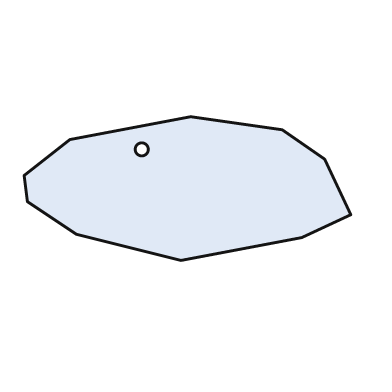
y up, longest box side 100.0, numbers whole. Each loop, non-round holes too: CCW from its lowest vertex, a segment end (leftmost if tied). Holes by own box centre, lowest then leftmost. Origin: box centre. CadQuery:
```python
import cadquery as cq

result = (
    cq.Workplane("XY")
    .moveTo(-2.0, -22.0)
    .lineTo(35.0, -15.0)
    .lineTo(50.0, -8.0)
    .lineTo(42.0, 9.0)
    .lineTo(29.0, 18.0)
    .lineTo(1.0, 22.0)
    .lineTo(-36.0, 15.0)
    .lineTo(-50.0, 4.0)
    .lineTo(-49.0, -4.0)
    .lineTo(-34.0, -14.0)
    .close()
    .moveTo(-14.0, 12.0)
    .circle(2.0)
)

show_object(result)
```